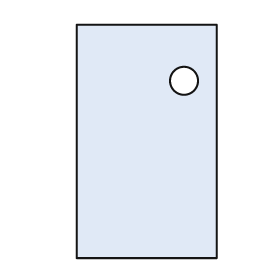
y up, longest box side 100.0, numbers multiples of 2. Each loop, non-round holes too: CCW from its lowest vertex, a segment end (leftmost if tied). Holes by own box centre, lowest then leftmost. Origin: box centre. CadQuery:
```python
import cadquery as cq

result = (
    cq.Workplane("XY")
    .moveTo(-30.0, -50.0)
    .lineTo(30.0, -50.0)
    .lineTo(30.0, 50.0)
    .lineTo(-30.0, 50.0)
    .close()
    .moveTo(16.0, 26.0)
    .circle(6.0)
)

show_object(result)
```